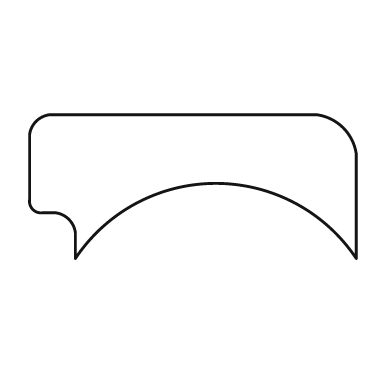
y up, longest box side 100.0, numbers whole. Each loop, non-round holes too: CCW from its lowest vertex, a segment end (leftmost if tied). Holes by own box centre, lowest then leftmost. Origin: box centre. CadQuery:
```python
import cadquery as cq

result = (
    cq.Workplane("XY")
    .moveTo(-36.0, -22.0)
    .threePointArc((7.0, 1.0), (50.0, -22.0))
    .lineTo(50.0, 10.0)
    .threePointArc((46.0, 18.0), (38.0, 22.0))
    .lineTo(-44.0, 22.0)
    .threePointArc((-48.0, 20.0), (-50.0, 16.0))
    .lineTo(-50.0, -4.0)
    .threePointArc((-49.0, -7.0), (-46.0, -8.0))
    .lineTo(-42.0, -8.0)
    .threePointArc((-38.0, -10.0), (-36.0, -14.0))
    .close()
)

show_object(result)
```